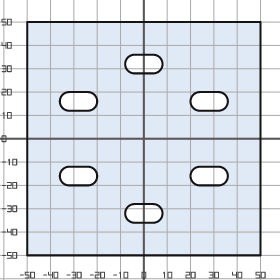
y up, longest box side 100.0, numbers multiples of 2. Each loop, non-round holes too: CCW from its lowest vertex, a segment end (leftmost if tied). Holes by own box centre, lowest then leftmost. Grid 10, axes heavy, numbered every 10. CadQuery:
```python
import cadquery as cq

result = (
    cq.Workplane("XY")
    .moveTo(-50.0, -50.0)
    .lineTo(50.0, -50.0)
    .lineTo(50.0, 50.0)
    .lineTo(-50.0, 50.0)
    .close()
    .moveTo(-4.0, -36.0)
    .lineTo(4.0, -36.0)
    .threePointArc((8.0, -32.0), (4.0, -28.0))
    .lineTo(-4.0, -28.0)
    .threePointArc((-8.0, -32.0), (-4.0, -36.0))
    .close()
    .moveTo(-32.0, -20.0)
    .lineTo(-24.0, -20.0)
    .threePointArc((-20.0, -16.0), (-24.0, -12.0))
    .lineTo(-32.0, -12.0)
    .threePointArc((-36.0, -16.0), (-32.0, -20.0))
    .close()
    .moveTo(24.0, -20.0)
    .lineTo(32.0, -20.0)
    .threePointArc((36.0, -16.0), (32.0, -12.0))
    .lineTo(24.0, -12.0)
    .threePointArc((20.0, -16.0), (24.0, -20.0))
    .close()
    .moveTo(-32.0, 12.0)
    .lineTo(-24.0, 12.0)
    .threePointArc((-20.0, 16.0), (-24.0, 20.0))
    .lineTo(-32.0, 20.0)
    .threePointArc((-36.0, 16.0), (-32.0, 12.0))
    .close()
    .moveTo(24.0, 12.0)
    .lineTo(32.0, 12.0)
    .threePointArc((36.0, 16.0), (32.0, 20.0))
    .lineTo(24.0, 20.0)
    .threePointArc((20.0, 16.0), (24.0, 12.0))
    .close()
    .moveTo(-4.0, 28.0)
    .lineTo(4.0, 28.0)
    .threePointArc((8.0, 32.0), (4.0, 36.0))
    .lineTo(-4.0, 36.0)
    .threePointArc((-8.0, 32.0), (-4.0, 28.0))
    .close()
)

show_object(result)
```